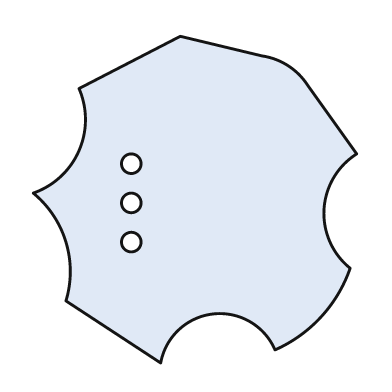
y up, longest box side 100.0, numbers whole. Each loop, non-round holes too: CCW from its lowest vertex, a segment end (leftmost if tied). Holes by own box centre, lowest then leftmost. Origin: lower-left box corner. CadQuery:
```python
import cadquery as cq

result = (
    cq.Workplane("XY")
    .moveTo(39.0, 0.0)
    .threePointArc((55.0, 15.0), (74.0, 4.0))
    .threePointArc((88.0, 14.0), (97.0, 29.0))
    .threePointArc((89.0, 47.0), (99.0, 64.0))
    .lineTo(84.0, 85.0)
    .threePointArc((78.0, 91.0), (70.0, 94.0))
    .lineTo(45.0, 100.0)
    .lineTo(14.0, 84.0)
    .threePointArc((14.0, 65.0), (0.0, 52.0))
    .threePointArc((10.0, 37.0), (10.0, 19.0))
    .close()
    .moveTo(30.0, 37.0)
    .circle(3.0)
    .moveTo(30.0, 49.0)
    .circle(3.0)
    .moveTo(30.0, 61.0)
    .circle(3.0)
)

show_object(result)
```